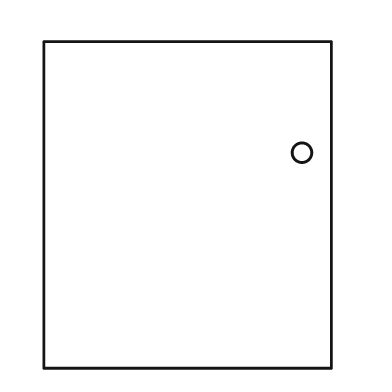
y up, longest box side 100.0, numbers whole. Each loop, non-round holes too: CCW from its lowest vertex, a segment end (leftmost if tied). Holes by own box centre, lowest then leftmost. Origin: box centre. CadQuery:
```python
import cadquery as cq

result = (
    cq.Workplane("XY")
    .moveTo(-44.0, -50.0)
    .lineTo(44.0, -50.0)
    .lineTo(44.0, 50.0)
    .lineTo(-44.0, 50.0)
    .close()
    .moveTo(35.0, 16.0)
    .circle(3.0)
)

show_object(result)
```